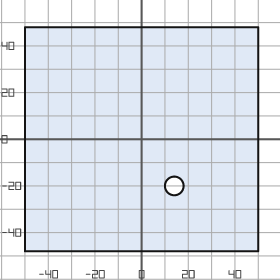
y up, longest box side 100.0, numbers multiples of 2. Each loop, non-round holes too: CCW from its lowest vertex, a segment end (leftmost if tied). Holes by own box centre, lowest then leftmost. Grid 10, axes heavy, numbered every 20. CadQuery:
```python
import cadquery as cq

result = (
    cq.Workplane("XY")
    .moveTo(-50.0, -48.0)
    .lineTo(50.0, -48.0)
    .lineTo(50.0, 48.0)
    .lineTo(-50.0, 48.0)
    .close()
    .moveTo(14.0, -20.0)
    .circle(4.0)
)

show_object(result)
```